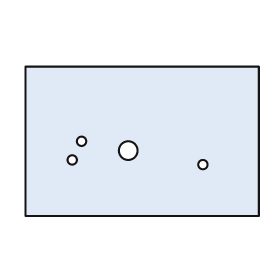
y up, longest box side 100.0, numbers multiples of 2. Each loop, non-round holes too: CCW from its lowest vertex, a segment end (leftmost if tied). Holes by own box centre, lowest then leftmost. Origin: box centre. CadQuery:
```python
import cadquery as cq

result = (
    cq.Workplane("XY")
    .moveTo(-50.0, -32.0)
    .lineTo(50.0, -32.0)
    .lineTo(50.0, 32.0)
    .lineTo(-50.0, 32.0)
    .close()
    .moveTo(26.0, -10.0)
    .circle(2.0)
    .moveTo(-30.0, -8.0)
    .circle(2.0)
    .moveTo(-6.0, -4.0)
    .circle(4.0)
    .moveTo(-26.0, 0.0)
    .circle(2.0)
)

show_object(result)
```